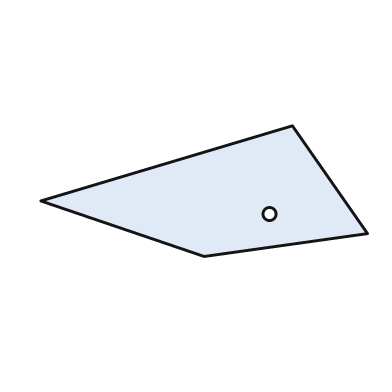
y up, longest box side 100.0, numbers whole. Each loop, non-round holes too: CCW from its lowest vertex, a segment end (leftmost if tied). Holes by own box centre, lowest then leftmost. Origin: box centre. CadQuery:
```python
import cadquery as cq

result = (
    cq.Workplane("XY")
    .moveTo(0.0, -20.0)
    .lineTo(50.0, -13.0)
    .lineTo(27.0, 20.0)
    .lineTo(-50.0, -3.0)
    .close()
    .moveTo(20.0, -7.0)
    .circle(2.0)
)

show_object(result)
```